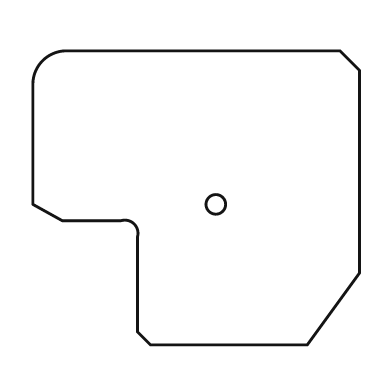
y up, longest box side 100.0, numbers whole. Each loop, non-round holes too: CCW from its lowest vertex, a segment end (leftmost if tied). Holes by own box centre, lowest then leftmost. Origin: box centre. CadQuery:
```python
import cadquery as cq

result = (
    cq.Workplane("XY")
    .moveTo(-14.0, -45.0)
    .lineTo(34.0, -45.0)
    .lineTo(50.0, -23.0)
    .lineTo(50.0, 39.0)
    .lineTo(44.0, 45.0)
    .lineTo(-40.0, 45.0)
    .threePointArc((-47.0, 42.0), (-50.0, 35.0))
    .lineTo(-50.0, -2.0)
    .lineTo(-41.0, -7.0)
    .lineTo(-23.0, -7.0)
    .threePointArc((-19.0, -8.0), (-18.0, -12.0))
    .lineTo(-18.0, -41.0)
    .close()
    .moveTo(6.0, -2.0)
    .circle(3.0)
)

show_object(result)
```